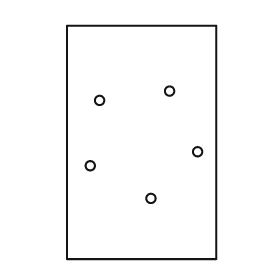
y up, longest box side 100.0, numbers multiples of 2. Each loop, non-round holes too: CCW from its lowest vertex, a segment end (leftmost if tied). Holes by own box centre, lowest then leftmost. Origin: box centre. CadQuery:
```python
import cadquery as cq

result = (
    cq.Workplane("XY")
    .moveTo(-32.0, -50.0)
    .lineTo(32.0, -50.0)
    .lineTo(32.0, 50.0)
    .lineTo(-32.0, 50.0)
    .close()
    .moveTo(4.0, -24.0)
    .circle(2.0)
    .moveTo(-22.0, -10.0)
    .circle(2.0)
    .moveTo(24.0, -4.0)
    .circle(2.0)
    .moveTo(-18.0, 18.0)
    .circle(2.0)
    .moveTo(12.0, 22.0)
    .circle(2.0)
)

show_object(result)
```